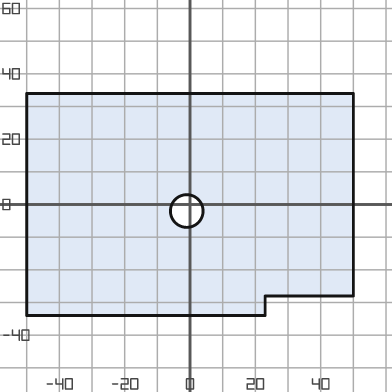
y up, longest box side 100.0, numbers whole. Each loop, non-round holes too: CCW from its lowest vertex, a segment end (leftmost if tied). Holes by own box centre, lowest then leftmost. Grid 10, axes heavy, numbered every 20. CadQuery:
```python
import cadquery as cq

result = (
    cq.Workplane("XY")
    .moveTo(-50.0, -34.0)
    .lineTo(23.0, -34.0)
    .lineTo(23.0, -28.0)
    .lineTo(50.0, -28.0)
    .lineTo(50.0, 34.0)
    .lineTo(-50.0, 34.0)
    .close()
    .moveTo(-1.0, -2.0)
    .circle(5.0)
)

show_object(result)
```